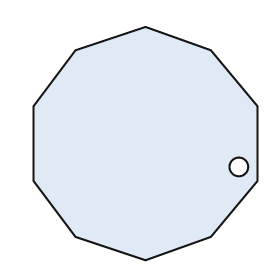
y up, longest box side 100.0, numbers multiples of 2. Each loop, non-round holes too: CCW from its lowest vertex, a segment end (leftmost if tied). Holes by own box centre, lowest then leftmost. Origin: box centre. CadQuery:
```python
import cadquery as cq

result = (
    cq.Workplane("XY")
    .moveTo(0.0, -50.0)
    .lineTo(28.0, -40.0)
    .lineTo(48.0, -16.0)
    .lineTo(48.0, 16.0)
    .lineTo(28.0, 40.0)
    .lineTo(0.0, 50.0)
    .lineTo(-30.0, 40.0)
    .lineTo(-48.0, 16.0)
    .lineTo(-48.0, -16.0)
    .lineTo(-30.0, -40.0)
    .close()
    .moveTo(40.0, -10.0)
    .circle(4.0)
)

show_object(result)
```